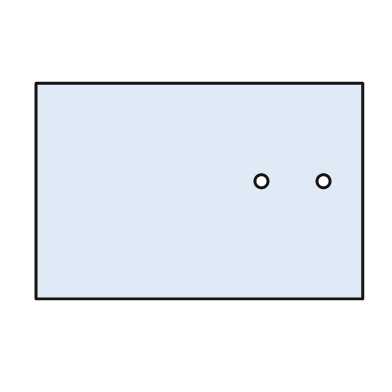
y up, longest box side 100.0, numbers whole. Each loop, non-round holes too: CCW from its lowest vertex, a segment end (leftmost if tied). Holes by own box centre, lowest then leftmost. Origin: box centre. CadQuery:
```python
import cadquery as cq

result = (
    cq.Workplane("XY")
    .moveTo(-50.0, -33.0)
    .lineTo(50.0, -33.0)
    .lineTo(50.0, 33.0)
    .lineTo(-50.0, 33.0)
    .close()
    .moveTo(19.0, 3.0)
    .circle(2.0)
    .moveTo(38.0, 3.0)
    .circle(2.0)
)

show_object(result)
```